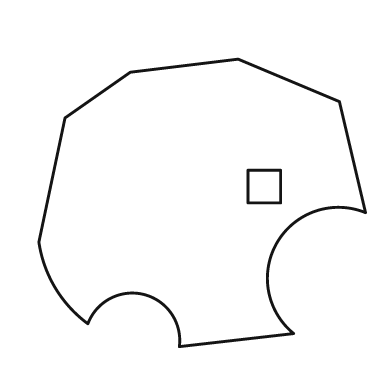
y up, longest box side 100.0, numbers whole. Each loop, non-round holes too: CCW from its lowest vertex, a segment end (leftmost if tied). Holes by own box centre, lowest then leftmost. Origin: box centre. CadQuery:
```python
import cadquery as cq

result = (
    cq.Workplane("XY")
    .moveTo(-7.0, -44.0)
    .lineTo(28.0, -40.0)
    .threePointArc((23.0, -12.0), (50.0, -3.0))
    .lineTo(42.0, 31.0)
    .lineTo(11.0, 44.0)
    .lineTo(-22.0, 40.0)
    .lineTo(-42.0, 26.0)
    .lineTo(-50.0, -12.0)
    .threePointArc((-45.0, -26.0), (-35.0, -37.0))
    .threePointArc((-18.0, -28.0), (-7.0, -44.0))
    .close()
    .moveTo(14.0, 0.0)
    .lineTo(24.0, 0.0)
    .lineTo(24.0, 10.0)
    .lineTo(14.0, 10.0)
    .close()
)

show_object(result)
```